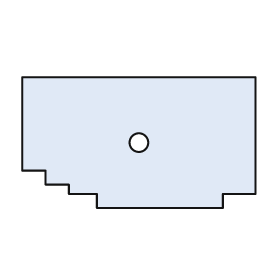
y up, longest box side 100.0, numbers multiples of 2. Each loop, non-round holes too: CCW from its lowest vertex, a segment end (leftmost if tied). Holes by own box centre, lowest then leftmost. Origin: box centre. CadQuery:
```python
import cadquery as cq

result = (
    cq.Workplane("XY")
    .moveTo(-18.0, -28.0)
    .lineTo(36.0, -28.0)
    .lineTo(36.0, -22.0)
    .lineTo(50.0, -22.0)
    .lineTo(50.0, 28.0)
    .lineTo(-50.0, 28.0)
    .lineTo(-50.0, -12.0)
    .lineTo(-40.0, -12.0)
    .lineTo(-40.0, -18.0)
    .lineTo(-30.0, -18.0)
    .lineTo(-30.0, -22.0)
    .lineTo(-18.0, -22.0)
    .close()
    .moveTo(0.0, 0.0)
    .circle(4.0)
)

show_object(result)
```